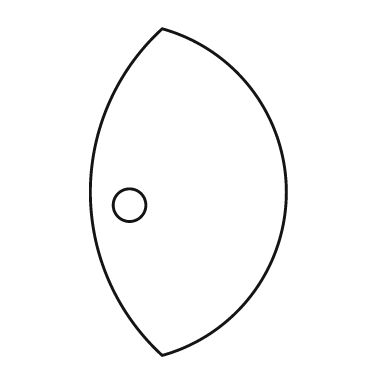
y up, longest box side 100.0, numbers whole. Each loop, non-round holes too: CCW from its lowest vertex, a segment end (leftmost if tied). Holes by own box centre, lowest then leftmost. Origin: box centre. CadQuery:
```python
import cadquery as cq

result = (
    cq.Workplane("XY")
    .moveTo(-8.0, -50.0)
    .threePointArc((30.0, 0.0), (-8.0, 50.0))
    .threePointArc((-30.0, 0.0), (-8.0, -50.0))
    .close()
    .moveTo(-18.0, -4.0)
    .circle(5.0)
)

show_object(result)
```